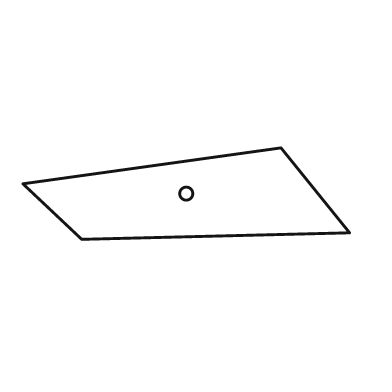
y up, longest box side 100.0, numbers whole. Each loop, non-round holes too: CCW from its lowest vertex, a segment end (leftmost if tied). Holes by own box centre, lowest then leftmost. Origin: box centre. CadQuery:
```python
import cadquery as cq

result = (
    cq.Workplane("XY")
    .moveTo(-32.0, -14.0)
    .lineTo(50.0, -12.0)
    .lineTo(29.0, 14.0)
    .lineTo(-50.0, 3.0)
    .close()
    .moveTo(0.0, 0.0)
    .circle(2.0)
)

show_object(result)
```